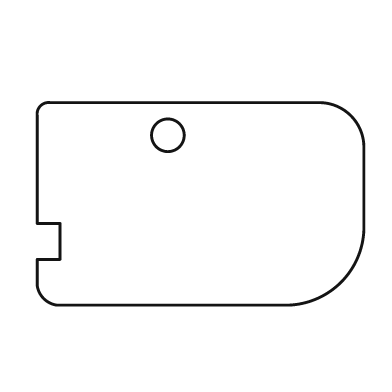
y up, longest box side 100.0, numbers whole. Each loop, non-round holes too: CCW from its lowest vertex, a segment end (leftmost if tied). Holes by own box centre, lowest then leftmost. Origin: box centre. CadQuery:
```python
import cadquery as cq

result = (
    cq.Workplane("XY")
    .moveTo(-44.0, -31.0)
    .lineTo(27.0, -31.0)
    .threePointArc((43.0, -24.0), (50.0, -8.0))
    .lineTo(50.0, 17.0)
    .threePointArc((46.0, 27.0), (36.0, 31.0))
    .lineTo(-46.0, 31.0)
    .threePointArc((-49.0, 30.0), (-50.0, 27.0))
    .lineTo(-50.0, -6.0)
    .lineTo(-43.0, -6.0)
    .lineTo(-43.0, -17.0)
    .lineTo(-50.0, -17.0)
    .lineTo(-50.0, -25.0)
    .threePointArc((-48.0, -29.0), (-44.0, -31.0))
    .close()
    .moveTo(-10.0, 21.0)
    .circle(5.0)
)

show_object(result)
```